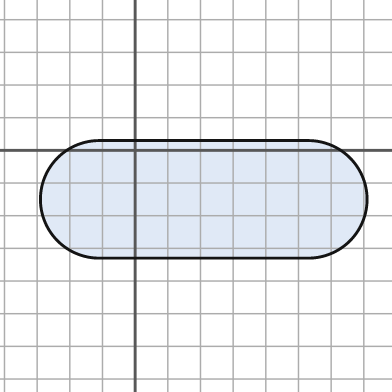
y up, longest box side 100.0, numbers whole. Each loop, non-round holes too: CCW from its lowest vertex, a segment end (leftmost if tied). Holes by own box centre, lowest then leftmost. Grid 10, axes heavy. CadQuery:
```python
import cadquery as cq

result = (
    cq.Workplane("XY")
    .moveTo(-11.0, -33.0)
    .lineTo(53.0, -33.0)
    .threePointArc((71.0, -15.0), (53.0, 3.0))
    .lineTo(-11.0, 3.0)
    .threePointArc((-29.0, -15.0), (-11.0, -33.0))
    .close()
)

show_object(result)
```